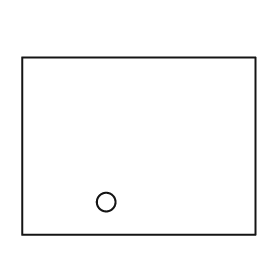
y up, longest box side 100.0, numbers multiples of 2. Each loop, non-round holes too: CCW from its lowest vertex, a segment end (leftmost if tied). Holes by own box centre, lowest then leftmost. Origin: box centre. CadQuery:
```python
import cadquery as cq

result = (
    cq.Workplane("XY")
    .moveTo(-50.0, -38.0)
    .lineTo(50.0, -38.0)
    .lineTo(50.0, 38.0)
    .lineTo(-50.0, 38.0)
    .close()
    .moveTo(-14.0, -24.0)
    .circle(4.0)
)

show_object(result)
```